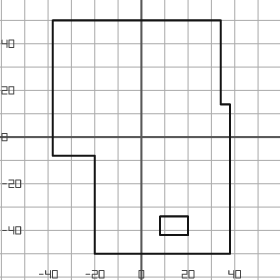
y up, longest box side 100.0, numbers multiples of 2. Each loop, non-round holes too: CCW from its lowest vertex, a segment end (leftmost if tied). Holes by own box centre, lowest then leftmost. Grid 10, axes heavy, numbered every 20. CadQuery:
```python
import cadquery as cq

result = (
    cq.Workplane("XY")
    .moveTo(-20.0, -50.0)
    .lineTo(38.0, -50.0)
    .lineTo(38.0, 14.0)
    .lineTo(34.0, 14.0)
    .lineTo(34.0, 50.0)
    .lineTo(-38.0, 50.0)
    .lineTo(-38.0, -8.0)
    .lineTo(-20.0, -8.0)
    .close()
    .moveTo(8.0, -42.0)
    .lineTo(20.0, -42.0)
    .lineTo(20.0, -34.0)
    .lineTo(8.0, -34.0)
    .close()
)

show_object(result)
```